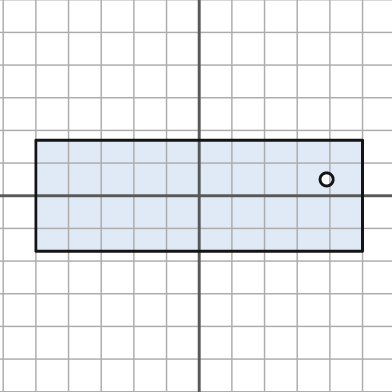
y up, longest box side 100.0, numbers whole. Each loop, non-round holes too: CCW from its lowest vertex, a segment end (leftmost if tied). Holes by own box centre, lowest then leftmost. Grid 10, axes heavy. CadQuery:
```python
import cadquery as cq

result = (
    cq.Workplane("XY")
    .moveTo(-50.0, -17.0)
    .lineTo(50.0, -17.0)
    .lineTo(50.0, 17.0)
    .lineTo(-50.0, 17.0)
    .close()
    .moveTo(39.0, 5.0)
    .circle(2.0)
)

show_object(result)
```